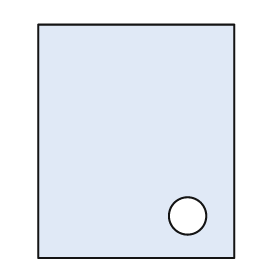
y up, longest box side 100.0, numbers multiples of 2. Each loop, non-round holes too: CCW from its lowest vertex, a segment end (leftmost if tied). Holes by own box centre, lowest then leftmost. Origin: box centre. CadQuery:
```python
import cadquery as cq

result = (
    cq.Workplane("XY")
    .moveTo(-42.0, -50.0)
    .lineTo(42.0, -50.0)
    .lineTo(42.0, 50.0)
    .lineTo(-42.0, 50.0)
    .close()
    .moveTo(22.0, -32.0)
    .circle(8.0)
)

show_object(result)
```